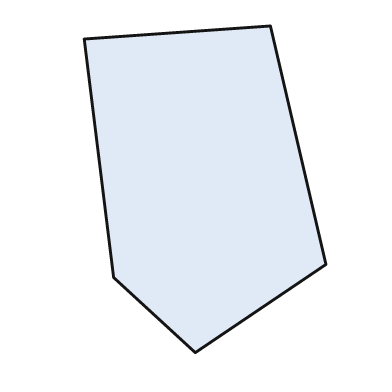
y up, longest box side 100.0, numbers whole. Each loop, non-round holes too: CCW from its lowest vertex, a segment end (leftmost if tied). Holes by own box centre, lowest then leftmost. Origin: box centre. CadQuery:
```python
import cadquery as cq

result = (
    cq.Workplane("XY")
    .moveTo(-3.0, -50.0)
    .lineTo(37.0, -23.0)
    .lineTo(20.0, 50.0)
    .lineTo(-37.0, 46.0)
    .lineTo(-28.0, -27.0)
    .close()
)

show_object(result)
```